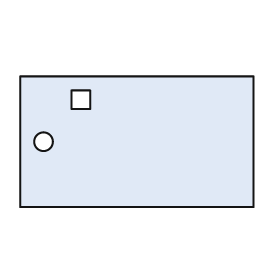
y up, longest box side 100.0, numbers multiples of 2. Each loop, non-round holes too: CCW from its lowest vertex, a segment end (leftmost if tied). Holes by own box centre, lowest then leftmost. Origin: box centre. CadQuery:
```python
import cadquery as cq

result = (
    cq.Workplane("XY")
    .moveTo(-50.0, -28.0)
    .lineTo(50.0, -28.0)
    .lineTo(50.0, 28.0)
    .lineTo(-50.0, 28.0)
    .close()
    .moveTo(-40.0, 0.0)
    .circle(4.0)
    .moveTo(-28.0, 14.0)
    .lineTo(-20.0, 14.0)
    .lineTo(-20.0, 22.0)
    .lineTo(-28.0, 22.0)
    .close()
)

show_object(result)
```